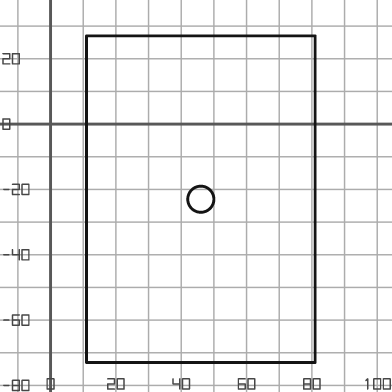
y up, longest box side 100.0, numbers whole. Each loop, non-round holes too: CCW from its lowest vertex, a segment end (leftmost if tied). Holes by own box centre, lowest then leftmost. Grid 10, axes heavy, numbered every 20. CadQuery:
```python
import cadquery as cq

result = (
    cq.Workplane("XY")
    .moveTo(11.0, -73.0)
    .lineTo(81.0, -73.0)
    .lineTo(81.0, 27.0)
    .lineTo(11.0, 27.0)
    .close()
    .moveTo(46.0, -23.0)
    .circle(4.0)
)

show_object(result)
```